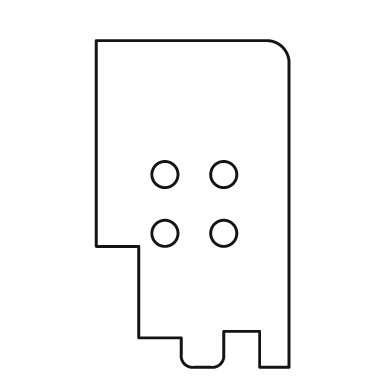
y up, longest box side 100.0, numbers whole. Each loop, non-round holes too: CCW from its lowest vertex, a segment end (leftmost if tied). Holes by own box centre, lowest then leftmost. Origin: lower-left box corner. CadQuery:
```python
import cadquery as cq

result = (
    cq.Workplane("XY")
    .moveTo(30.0, 0.0)
    .lineTo(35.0, 0.0)
    .threePointArc((38.0, 1.0), (39.0, 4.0))
    .lineTo(39.0, 11.0)
    .lineTo(50.0, 11.0)
    .lineTo(50.0, 0.0)
    .lineTo(59.0, 0.0)
    .lineTo(59.0, 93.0)
    .threePointArc((57.0, 98.0), (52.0, 100.0))
    .lineTo(0.0, 100.0)
    .lineTo(0.0, 37.0)
    .lineTo(13.0, 37.0)
    .lineTo(13.0, 9.0)
    .lineTo(26.0, 9.0)
    .lineTo(26.0, 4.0)
    .threePointArc((27.0, 1.0), (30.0, 0.0))
    .close()
    .moveTo(21.0, 41.0)
    .circle(4.0)
    .moveTo(39.0, 41.0)
    .circle(4.0)
    .moveTo(21.0, 59.0)
    .circle(4.0)
    .moveTo(39.0, 59.0)
    .circle(4.0)
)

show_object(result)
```